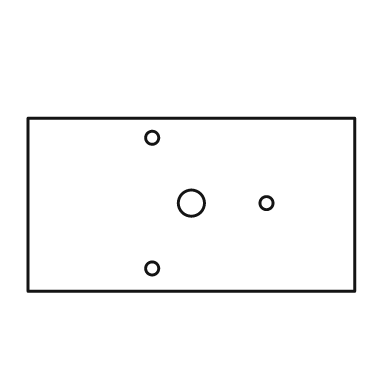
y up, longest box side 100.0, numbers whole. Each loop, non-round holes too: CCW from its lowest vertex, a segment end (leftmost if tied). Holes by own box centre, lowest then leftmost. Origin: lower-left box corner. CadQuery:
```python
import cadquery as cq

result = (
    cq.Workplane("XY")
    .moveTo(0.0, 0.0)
    .lineTo(100.0, 0.0)
    .lineTo(100.0, 53.0)
    .lineTo(0.0, 53.0)
    .close()
    .moveTo(38.0, 7.0)
    .circle(2.0)
    .moveTo(50.0, 27.0)
    .circle(4.0)
    .moveTo(73.0, 27.0)
    .circle(2.0)
    .moveTo(38.0, 47.0)
    .circle(2.0)
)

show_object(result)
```